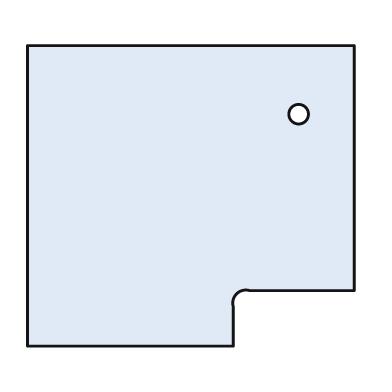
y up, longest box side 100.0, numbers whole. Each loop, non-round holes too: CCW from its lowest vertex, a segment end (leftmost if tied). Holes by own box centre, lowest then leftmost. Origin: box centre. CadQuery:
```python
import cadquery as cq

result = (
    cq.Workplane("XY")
    .moveTo(-50.0, -46.0)
    .lineTo(13.0, -46.0)
    .lineTo(13.0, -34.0)
    .threePointArc((14.0, -30.0), (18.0, -29.0))
    .lineTo(50.0, -29.0)
    .lineTo(50.0, 46.0)
    .lineTo(-50.0, 46.0)
    .close()
    .moveTo(33.0, 25.0)
    .circle(3.0)
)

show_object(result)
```